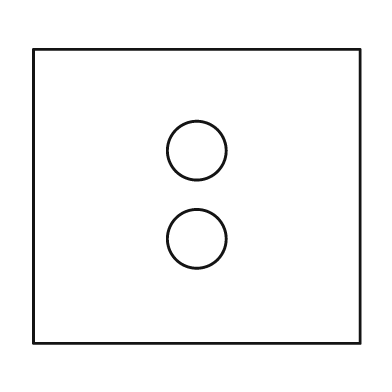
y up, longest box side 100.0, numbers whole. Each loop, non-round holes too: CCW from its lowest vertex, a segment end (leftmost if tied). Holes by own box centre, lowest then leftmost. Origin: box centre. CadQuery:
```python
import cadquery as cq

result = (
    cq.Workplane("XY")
    .moveTo(-50.0, -45.0)
    .lineTo(50.0, -45.0)
    .lineTo(50.0, 45.0)
    .lineTo(-50.0, 45.0)
    .close()
    .moveTo(0.0, -13.0)
    .circle(9.0)
    .moveTo(0.0, 14.0)
    .circle(9.0)
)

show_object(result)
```